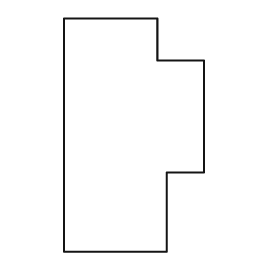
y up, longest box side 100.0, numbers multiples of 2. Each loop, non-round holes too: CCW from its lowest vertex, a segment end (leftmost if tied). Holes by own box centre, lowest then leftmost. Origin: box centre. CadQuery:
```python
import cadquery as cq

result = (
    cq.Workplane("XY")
    .moveTo(-30.0, -50.0)
    .lineTo(14.0, -50.0)
    .lineTo(14.0, -16.0)
    .lineTo(30.0, -16.0)
    .lineTo(30.0, 32.0)
    .lineTo(10.0, 32.0)
    .lineTo(10.0, 50.0)
    .lineTo(-30.0, 50.0)
    .close()
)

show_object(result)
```